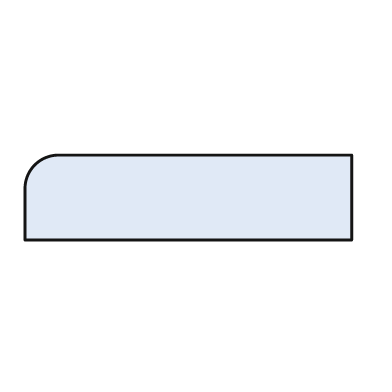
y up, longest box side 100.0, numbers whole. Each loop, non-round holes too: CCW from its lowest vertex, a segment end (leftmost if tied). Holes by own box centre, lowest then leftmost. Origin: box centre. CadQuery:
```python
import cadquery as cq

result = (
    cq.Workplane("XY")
    .moveTo(-50.0, -13.0)
    .lineTo(50.0, -13.0)
    .lineTo(50.0, 13.0)
    .lineTo(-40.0, 13.0)
    .threePointArc((-47.0, 10.0), (-50.0, 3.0))
    .close()
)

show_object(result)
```